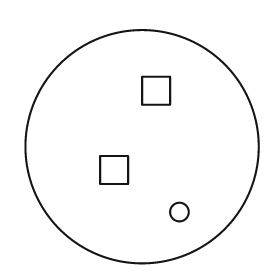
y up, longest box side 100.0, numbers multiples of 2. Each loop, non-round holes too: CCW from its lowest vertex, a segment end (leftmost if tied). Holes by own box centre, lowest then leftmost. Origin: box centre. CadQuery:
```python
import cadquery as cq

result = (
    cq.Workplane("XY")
    .moveTo(0.0, 0.0)
    .circle(50.0)
    .moveTo(16.0, -28.0)
    .circle(4.0)
    .moveTo(-18.0, -16.0)
    .lineTo(-6.0, -16.0)
    .lineTo(-6.0, -4.0)
    .lineTo(-18.0, -4.0)
    .close()
    .moveTo(0.0, 18.0)
    .lineTo(12.0, 18.0)
    .lineTo(12.0, 30.0)
    .lineTo(0.0, 30.0)
    .close()
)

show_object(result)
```